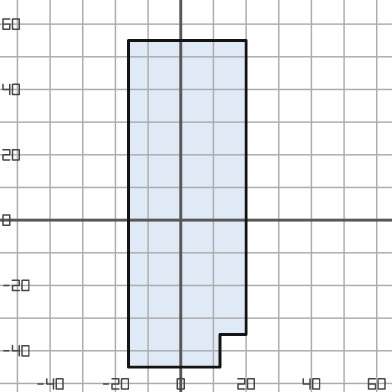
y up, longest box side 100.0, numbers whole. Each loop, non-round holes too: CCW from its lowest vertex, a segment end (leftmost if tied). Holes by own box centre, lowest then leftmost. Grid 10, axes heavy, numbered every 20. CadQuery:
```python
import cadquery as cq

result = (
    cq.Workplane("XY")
    .moveTo(-16.0, -45.0)
    .lineTo(12.0, -45.0)
    .lineTo(12.0, -35.0)
    .lineTo(20.0, -35.0)
    .lineTo(20.0, 55.0)
    .lineTo(-16.0, 55.0)
    .close()
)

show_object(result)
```